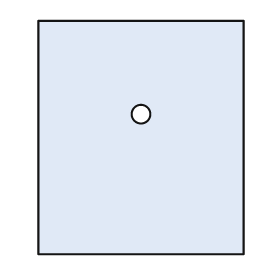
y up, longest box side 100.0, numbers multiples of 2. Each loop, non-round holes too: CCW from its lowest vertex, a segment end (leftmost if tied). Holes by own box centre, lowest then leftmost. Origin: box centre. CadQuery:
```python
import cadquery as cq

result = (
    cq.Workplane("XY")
    .moveTo(-44.0, -50.0)
    .lineTo(44.0, -50.0)
    .lineTo(44.0, 50.0)
    .lineTo(-44.0, 50.0)
    .close()
    .moveTo(0.0, 10.0)
    .circle(4.0)
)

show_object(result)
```